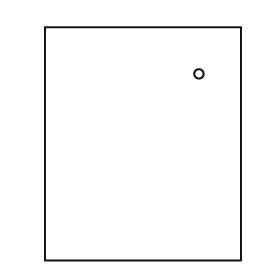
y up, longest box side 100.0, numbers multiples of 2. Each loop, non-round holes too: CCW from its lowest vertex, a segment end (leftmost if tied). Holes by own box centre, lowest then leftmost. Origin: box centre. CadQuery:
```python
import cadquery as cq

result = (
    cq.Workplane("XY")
    .moveTo(-42.0, -50.0)
    .lineTo(42.0, -50.0)
    .lineTo(42.0, 50.0)
    .lineTo(-42.0, 50.0)
    .close()
    .moveTo(24.0, 30.0)
    .circle(2.0)
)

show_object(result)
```